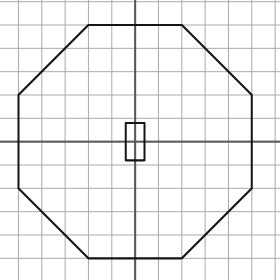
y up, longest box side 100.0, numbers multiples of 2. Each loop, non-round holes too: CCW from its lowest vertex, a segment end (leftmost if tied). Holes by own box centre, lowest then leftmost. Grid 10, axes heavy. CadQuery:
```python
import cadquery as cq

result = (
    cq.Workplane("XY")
    .moveTo(-20.0, -50.0)
    .lineTo(20.0, -50.0)
    .lineTo(50.0, -20.0)
    .lineTo(50.0, 20.0)
    .lineTo(20.0, 50.0)
    .lineTo(-20.0, 50.0)
    .lineTo(-50.0, 20.0)
    .lineTo(-50.0, -20.0)
    .close()
    .moveTo(-4.0, -8.0)
    .lineTo(4.0, -8.0)
    .lineTo(4.0, 8.0)
    .lineTo(-4.0, 8.0)
    .close()
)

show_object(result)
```